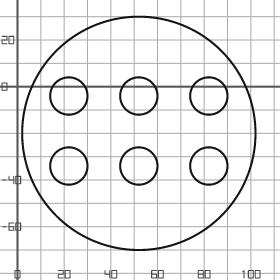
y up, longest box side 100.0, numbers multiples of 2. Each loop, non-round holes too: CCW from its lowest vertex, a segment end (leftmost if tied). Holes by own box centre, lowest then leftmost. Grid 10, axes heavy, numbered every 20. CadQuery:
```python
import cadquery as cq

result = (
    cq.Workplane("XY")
    .moveTo(52.0, -20.0)
    .circle(50.0)
    .moveTo(22.0, -34.0)
    .circle(8.0)
    .moveTo(52.0, -34.0)
    .circle(8.0)
    .moveTo(82.0, -34.0)
    .circle(8.0)
    .moveTo(22.0, -4.0)
    .circle(8.0)
    .moveTo(52.0, -4.0)
    .circle(8.0)
    .moveTo(82.0, -4.0)
    .circle(8.0)
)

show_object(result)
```